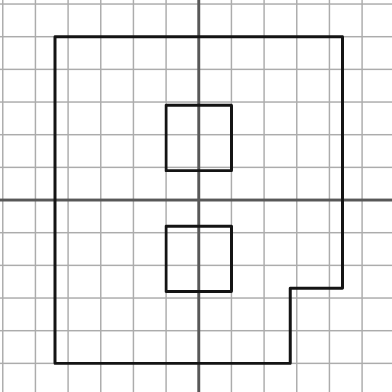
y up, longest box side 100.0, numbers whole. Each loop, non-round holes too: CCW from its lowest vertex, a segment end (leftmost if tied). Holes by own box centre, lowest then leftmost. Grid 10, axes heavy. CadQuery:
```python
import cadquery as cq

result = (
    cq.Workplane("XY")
    .moveTo(-44.0, -50.0)
    .lineTo(28.0, -50.0)
    .lineTo(28.0, -27.0)
    .lineTo(44.0, -27.0)
    .lineTo(44.0, 50.0)
    .lineTo(-44.0, 50.0)
    .close()
    .moveTo(-10.0, -28.0)
    .lineTo(10.0, -28.0)
    .lineTo(10.0, -8.0)
    .lineTo(-10.0, -8.0)
    .close()
    .moveTo(-10.0, 9.0)
    .lineTo(10.0, 9.0)
    .lineTo(10.0, 29.0)
    .lineTo(-10.0, 29.0)
    .close()
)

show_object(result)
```